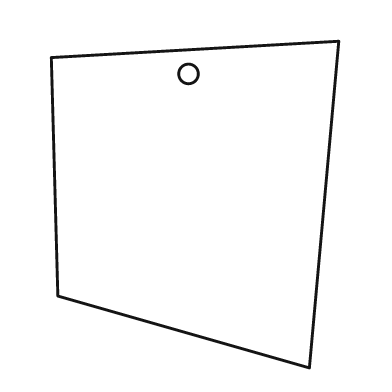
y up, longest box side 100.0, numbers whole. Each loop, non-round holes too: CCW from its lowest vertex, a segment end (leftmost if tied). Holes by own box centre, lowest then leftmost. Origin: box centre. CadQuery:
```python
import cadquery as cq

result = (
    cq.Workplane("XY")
    .moveTo(35.0, -50.0)
    .lineTo(44.0, 50.0)
    .lineTo(-44.0, 45.0)
    .lineTo(-42.0, -28.0)
    .close()
    .moveTo(-2.0, 40.0)
    .circle(3.0)
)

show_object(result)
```